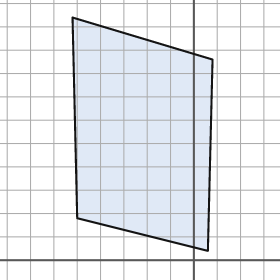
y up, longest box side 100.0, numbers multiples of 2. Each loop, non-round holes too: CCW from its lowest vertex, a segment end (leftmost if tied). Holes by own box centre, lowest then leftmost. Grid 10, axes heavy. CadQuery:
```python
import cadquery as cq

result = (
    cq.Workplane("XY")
    .moveTo(6.0, 4.0)
    .lineTo(8.0, 86.0)
    .lineTo(-52.0, 104.0)
    .lineTo(-50.0, 18.0)
    .close()
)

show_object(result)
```